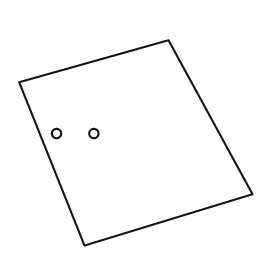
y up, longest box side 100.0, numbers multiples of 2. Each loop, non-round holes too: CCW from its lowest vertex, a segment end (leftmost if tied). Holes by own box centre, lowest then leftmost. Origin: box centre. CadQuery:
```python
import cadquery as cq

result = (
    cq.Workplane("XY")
    .moveTo(-22.0, -44.0)
    .lineTo(50.0, -22.0)
    .lineTo(14.0, 44.0)
    .lineTo(-50.0, 26.0)
    .close()
    .moveTo(-34.0, 4.0)
    .circle(2.0)
    .moveTo(-18.0, 4.0)
    .circle(2.0)
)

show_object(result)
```